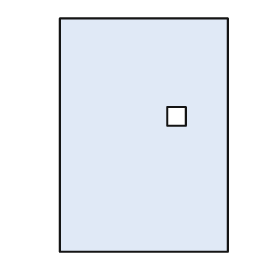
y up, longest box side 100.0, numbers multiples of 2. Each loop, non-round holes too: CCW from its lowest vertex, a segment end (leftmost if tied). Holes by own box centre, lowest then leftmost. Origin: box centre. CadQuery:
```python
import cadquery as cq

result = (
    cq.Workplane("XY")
    .moveTo(-36.0, -50.0)
    .lineTo(36.0, -50.0)
    .lineTo(36.0, 50.0)
    .lineTo(-36.0, 50.0)
    .close()
    .moveTo(10.0, 4.0)
    .lineTo(18.0, 4.0)
    .lineTo(18.0, 12.0)
    .lineTo(10.0, 12.0)
    .close()
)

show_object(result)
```